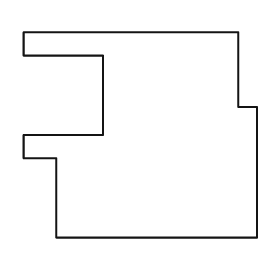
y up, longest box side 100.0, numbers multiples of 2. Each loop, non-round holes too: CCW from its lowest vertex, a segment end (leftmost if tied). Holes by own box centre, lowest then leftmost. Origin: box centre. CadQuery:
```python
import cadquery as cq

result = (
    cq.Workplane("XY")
    .moveTo(-36.0, -44.0)
    .lineTo(50.0, -44.0)
    .lineTo(50.0, 12.0)
    .lineTo(42.0, 12.0)
    .lineTo(42.0, 44.0)
    .lineTo(-50.0, 44.0)
    .lineTo(-50.0, 34.0)
    .lineTo(-16.0, 34.0)
    .lineTo(-16.0, 0.0)
    .lineTo(-50.0, 0.0)
    .lineTo(-50.0, -10.0)
    .lineTo(-36.0, -10.0)
    .close()
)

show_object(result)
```